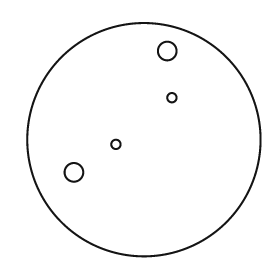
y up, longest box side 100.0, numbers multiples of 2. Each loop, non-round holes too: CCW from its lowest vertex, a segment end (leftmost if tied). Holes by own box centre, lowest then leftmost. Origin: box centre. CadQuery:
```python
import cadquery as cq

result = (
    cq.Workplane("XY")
    .moveTo(0.0, 0.0)
    .circle(50.0)
    .moveTo(-30.0, -14.0)
    .circle(4.0)
    .moveTo(-12.0, -2.0)
    .circle(2.0)
    .moveTo(12.0, 18.0)
    .circle(2.0)
    .moveTo(10.0, 38.0)
    .circle(4.0)
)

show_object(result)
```